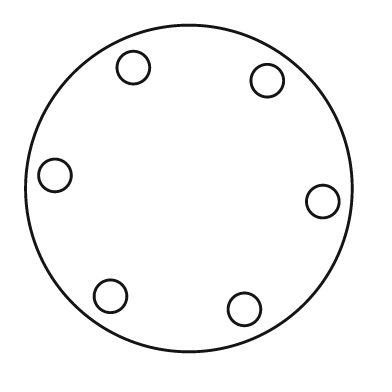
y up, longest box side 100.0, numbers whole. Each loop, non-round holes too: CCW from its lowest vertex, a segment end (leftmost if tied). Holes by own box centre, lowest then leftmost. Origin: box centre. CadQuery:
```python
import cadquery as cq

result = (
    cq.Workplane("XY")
    .moveTo(0.0, 0.0)
    .circle(50.0)
    .moveTo(17.0, -37.0)
    .circle(5.0)
    .moveTo(-24.0, -33.0)
    .circle(5.0)
    .moveTo(41.0, -4.0)
    .circle(5.0)
    .moveTo(-41.0, 4.0)
    .circle(5.0)
    .moveTo(24.0, 33.0)
    .circle(5.0)
    .moveTo(-17.0, 37.0)
    .circle(5.0)
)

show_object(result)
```